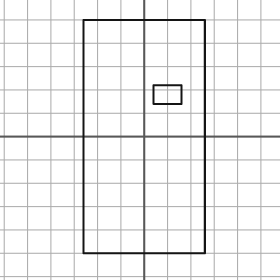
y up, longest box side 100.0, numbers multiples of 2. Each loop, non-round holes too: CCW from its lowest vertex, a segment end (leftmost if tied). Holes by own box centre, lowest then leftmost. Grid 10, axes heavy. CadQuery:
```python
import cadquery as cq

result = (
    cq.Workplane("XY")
    .moveTo(-26.0, -50.0)
    .lineTo(26.0, -50.0)
    .lineTo(26.0, 50.0)
    .lineTo(-26.0, 50.0)
    .close()
    .moveTo(4.0, 14.0)
    .lineTo(16.0, 14.0)
    .lineTo(16.0, 22.0)
    .lineTo(4.0, 22.0)
    .close()
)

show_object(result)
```